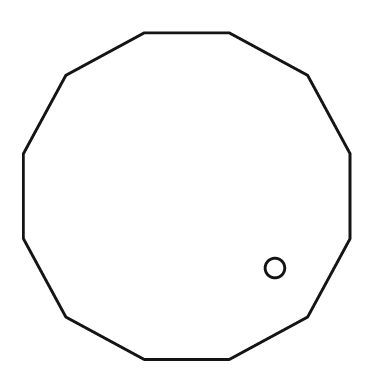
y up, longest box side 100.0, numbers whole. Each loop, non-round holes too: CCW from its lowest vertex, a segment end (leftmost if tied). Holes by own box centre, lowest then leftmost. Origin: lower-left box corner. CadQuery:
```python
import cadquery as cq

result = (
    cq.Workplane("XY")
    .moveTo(37.0, 0.0)
    .lineTo(63.0, 0.0)
    .lineTo(87.0, 13.0)
    .lineTo(100.0, 37.0)
    .lineTo(100.0, 63.0)
    .lineTo(87.0, 87.0)
    .lineTo(63.0, 100.0)
    .lineTo(37.0, 100.0)
    .lineTo(13.0, 87.0)
    .lineTo(0.0, 63.0)
    .lineTo(0.0, 37.0)
    .lineTo(13.0, 13.0)
    .close()
    .moveTo(77.0, 28.0)
    .circle(3.0)
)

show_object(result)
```